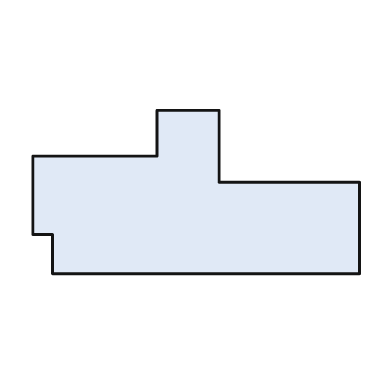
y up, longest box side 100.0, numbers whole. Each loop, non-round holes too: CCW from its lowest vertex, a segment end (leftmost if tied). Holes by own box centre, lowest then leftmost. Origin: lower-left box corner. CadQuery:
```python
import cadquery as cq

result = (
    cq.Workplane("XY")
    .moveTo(6.0, 0.0)
    .lineTo(100.0, 0.0)
    .lineTo(100.0, 28.0)
    .lineTo(57.0, 28.0)
    .lineTo(57.0, 50.0)
    .lineTo(38.0, 50.0)
    .lineTo(38.0, 36.0)
    .lineTo(0.0, 36.0)
    .lineTo(0.0, 12.0)
    .lineTo(6.0, 12.0)
    .close()
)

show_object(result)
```